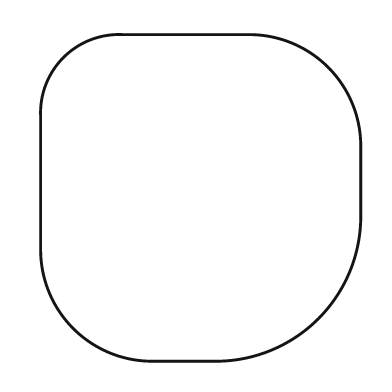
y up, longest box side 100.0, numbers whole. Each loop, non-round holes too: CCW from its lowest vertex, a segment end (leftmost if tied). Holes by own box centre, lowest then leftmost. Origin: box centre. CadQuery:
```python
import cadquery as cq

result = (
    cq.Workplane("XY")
    .moveTo(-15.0, -50.0)
    .lineTo(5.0, -50.0)
    .threePointArc((36.0, -37.0), (49.0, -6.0))
    .lineTo(49.0, 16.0)
    .threePointArc((39.0, 40.0), (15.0, 50.0))
    .lineTo(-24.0, 50.0)
    .threePointArc((-42.0, 43.0), (-49.0, 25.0))
    .lineTo(-49.0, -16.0)
    .threePointArc((-39.0, -40.0), (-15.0, -50.0))
    .close()
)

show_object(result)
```